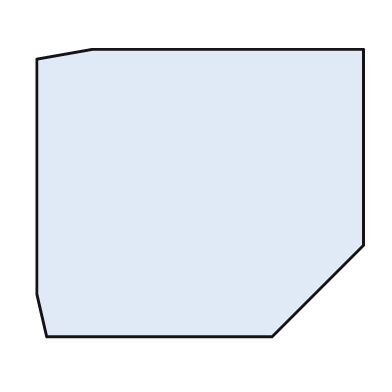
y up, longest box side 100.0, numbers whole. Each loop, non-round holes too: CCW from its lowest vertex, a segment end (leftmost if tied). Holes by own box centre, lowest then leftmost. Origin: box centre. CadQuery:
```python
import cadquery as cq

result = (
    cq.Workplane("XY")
    .moveTo(-47.0, -44.0)
    .lineTo(22.0, -44.0)
    .lineTo(50.0, -16.0)
    .lineTo(50.0, 44.0)
    .lineTo(-33.0, 44.0)
    .lineTo(-50.0, 41.0)
    .lineTo(-50.0, -31.0)
    .close()
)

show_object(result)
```